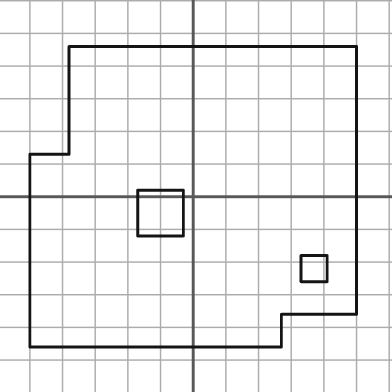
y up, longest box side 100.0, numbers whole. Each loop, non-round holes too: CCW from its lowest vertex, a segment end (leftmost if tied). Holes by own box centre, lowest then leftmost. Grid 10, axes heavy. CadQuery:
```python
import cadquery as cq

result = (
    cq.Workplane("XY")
    .moveTo(-50.0, -46.0)
    .lineTo(27.0, -46.0)
    .lineTo(27.0, -36.0)
    .lineTo(50.0, -36.0)
    .lineTo(50.0, 46.0)
    .lineTo(-38.0, 46.0)
    .lineTo(-38.0, 13.0)
    .lineTo(-50.0, 13.0)
    .close()
    .moveTo(33.0, -26.0)
    .lineTo(41.0, -26.0)
    .lineTo(41.0, -18.0)
    .lineTo(33.0, -18.0)
    .close()
    .moveTo(-17.0, -12.0)
    .lineTo(-3.0, -12.0)
    .lineTo(-3.0, 2.0)
    .lineTo(-17.0, 2.0)
    .close()
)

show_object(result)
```